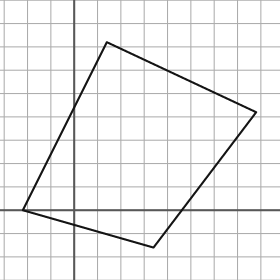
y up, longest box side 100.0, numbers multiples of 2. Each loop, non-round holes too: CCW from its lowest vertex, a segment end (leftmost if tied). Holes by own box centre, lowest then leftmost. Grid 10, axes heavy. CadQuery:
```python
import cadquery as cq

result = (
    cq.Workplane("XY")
    .moveTo(34.0, -16.0)
    .lineTo(78.0, 42.0)
    .lineTo(14.0, 72.0)
    .lineTo(-22.0, 0.0)
    .close()
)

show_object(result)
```